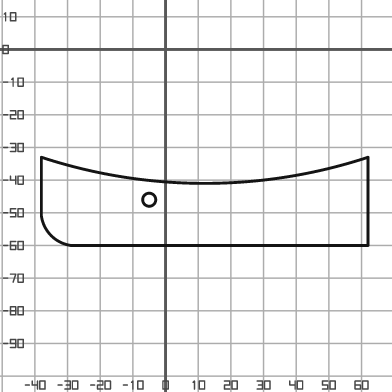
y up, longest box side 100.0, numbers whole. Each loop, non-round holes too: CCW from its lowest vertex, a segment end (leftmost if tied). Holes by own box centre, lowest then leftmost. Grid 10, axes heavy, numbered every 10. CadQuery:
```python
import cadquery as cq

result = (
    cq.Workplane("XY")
    .moveTo(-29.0, -60.0)
    .lineTo(62.0, -60.0)
    .lineTo(62.0, -33.0)
    .threePointArc((12.0, -41.0), (-38.0, -33.0))
    .lineTo(-38.0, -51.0)
    .threePointArc((-35.0, -57.0), (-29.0, -60.0))
    .close()
    .moveTo(-5.0, -46.0)
    .circle(2.0)
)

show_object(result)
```